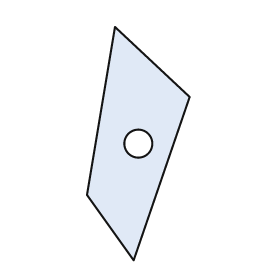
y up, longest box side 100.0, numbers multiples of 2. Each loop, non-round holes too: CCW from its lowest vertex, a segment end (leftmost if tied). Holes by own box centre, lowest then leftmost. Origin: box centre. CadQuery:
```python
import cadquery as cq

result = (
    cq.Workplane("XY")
    .moveTo(-2.0, -50.0)
    .lineTo(22.0, 20.0)
    .lineTo(-10.0, 50.0)
    .lineTo(-22.0, -22.0)
    .close()
    .moveTo(0.0, 0.0)
    .circle(6.0)
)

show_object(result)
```